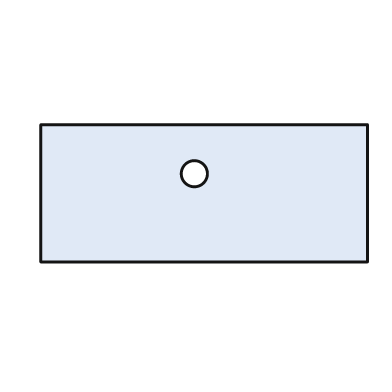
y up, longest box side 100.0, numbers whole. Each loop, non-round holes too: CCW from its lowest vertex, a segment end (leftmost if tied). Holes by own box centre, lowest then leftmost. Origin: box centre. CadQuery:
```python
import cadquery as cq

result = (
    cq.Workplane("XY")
    .moveTo(-50.0, -21.0)
    .lineTo(50.0, -21.0)
    .lineTo(50.0, 21.0)
    .lineTo(-50.0, 21.0)
    .close()
    .moveTo(-3.0, 6.0)
    .circle(4.0)
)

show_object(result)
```